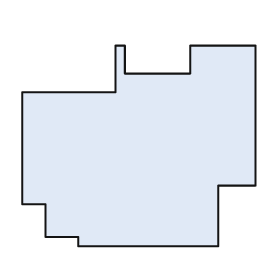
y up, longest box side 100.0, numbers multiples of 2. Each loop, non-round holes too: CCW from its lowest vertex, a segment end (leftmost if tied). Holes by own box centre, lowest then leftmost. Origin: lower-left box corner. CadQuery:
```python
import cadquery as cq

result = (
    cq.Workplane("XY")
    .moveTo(24.0, 0.0)
    .lineTo(84.0, 0.0)
    .lineTo(84.0, 26.0)
    .lineTo(100.0, 26.0)
    .lineTo(100.0, 86.0)
    .lineTo(72.0, 86.0)
    .lineTo(72.0, 74.0)
    .lineTo(44.0, 74.0)
    .lineTo(44.0, 86.0)
    .lineTo(40.0, 86.0)
    .lineTo(40.0, 66.0)
    .lineTo(0.0, 66.0)
    .lineTo(0.0, 18.0)
    .lineTo(10.0, 18.0)
    .lineTo(10.0, 4.0)
    .lineTo(24.0, 4.0)
    .close()
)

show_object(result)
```